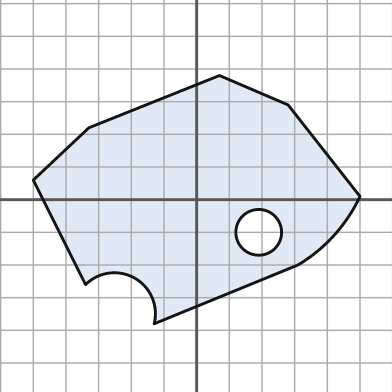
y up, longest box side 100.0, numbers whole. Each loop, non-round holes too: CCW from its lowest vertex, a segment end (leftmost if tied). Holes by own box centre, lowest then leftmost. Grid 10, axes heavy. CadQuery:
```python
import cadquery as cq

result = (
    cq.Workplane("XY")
    .moveTo(-13.0, -38.0)
    .lineTo(31.0, -20.0)
    .threePointArc((42.0, -11.0), (50.0, 1.0))
    .lineTo(28.0, 29.0)
    .lineTo(7.0, 38.0)
    .lineTo(-33.0, 22.0)
    .lineTo(-50.0, 6.0)
    .lineTo(-34.0, -26.0)
    .threePointArc((-19.0, -24.0), (-13.0, -38.0))
    .close()
    .moveTo(19.0, -10.0)
    .circle(7.0)
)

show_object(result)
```